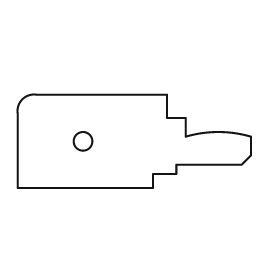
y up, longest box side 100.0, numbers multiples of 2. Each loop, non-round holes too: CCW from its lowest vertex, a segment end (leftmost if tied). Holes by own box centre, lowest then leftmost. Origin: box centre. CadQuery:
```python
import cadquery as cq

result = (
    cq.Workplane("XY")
    .moveTo(-50.0, -20.0)
    .lineTo(8.0, -20.0)
    .lineTo(8.0, -14.0)
    .lineTo(18.0, -14.0)
    .lineTo(18.0, -10.0)
    .lineTo(46.0, -10.0)
    .lineTo(50.0, -6.0)
    .lineTo(50.0, 2.0)
    .threePointArc((36.0, 4.0), (22.0, 2.0))
    .lineTo(22.0, 10.0)
    .lineTo(14.0, 10.0)
    .lineTo(14.0, 20.0)
    .lineTo(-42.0, 20.0)
    .threePointArc((-48.0, 18.0), (-50.0, 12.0))
    .close()
    .moveTo(-22.0, 0.0)
    .circle(4.0)
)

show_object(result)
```